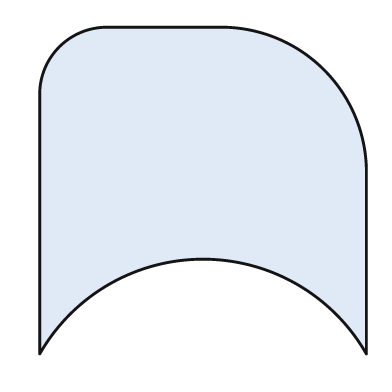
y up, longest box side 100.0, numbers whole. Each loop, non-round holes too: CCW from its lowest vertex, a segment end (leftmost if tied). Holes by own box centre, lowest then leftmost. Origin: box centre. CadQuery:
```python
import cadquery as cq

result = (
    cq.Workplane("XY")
    .moveTo(-50.0, -50.0)
    .threePointArc((0.0, -21.0), (50.0, -50.0))
    .lineTo(50.0, 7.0)
    .threePointArc((37.0, 37.0), (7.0, 50.0))
    .lineTo(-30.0, 50.0)
    .threePointArc((-44.0, 44.0), (-50.0, 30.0))
    .close()
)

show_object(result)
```